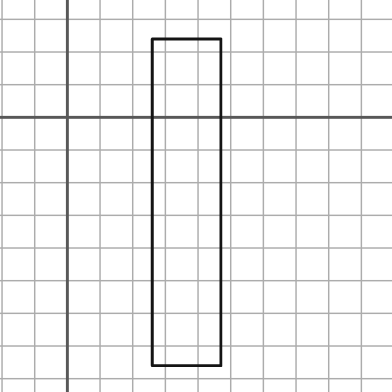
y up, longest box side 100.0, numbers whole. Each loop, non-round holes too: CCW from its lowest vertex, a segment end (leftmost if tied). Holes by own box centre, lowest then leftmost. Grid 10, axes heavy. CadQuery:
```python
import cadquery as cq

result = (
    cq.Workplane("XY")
    .moveTo(26.0, -76.0)
    .lineTo(47.0, -76.0)
    .lineTo(47.0, 24.0)
    .lineTo(26.0, 24.0)
    .close()
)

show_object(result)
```